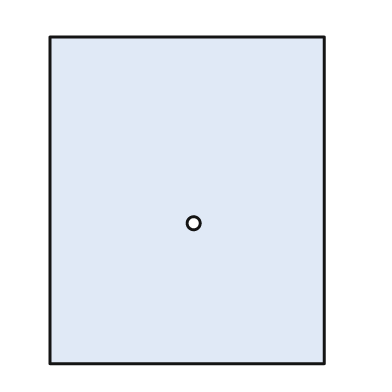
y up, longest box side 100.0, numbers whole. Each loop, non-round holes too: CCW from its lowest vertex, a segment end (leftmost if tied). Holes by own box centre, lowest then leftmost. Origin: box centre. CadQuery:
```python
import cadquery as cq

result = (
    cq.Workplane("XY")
    .moveTo(-42.0, -50.0)
    .lineTo(42.0, -50.0)
    .lineTo(42.0, 50.0)
    .lineTo(-42.0, 50.0)
    .close()
    .moveTo(2.0, -7.0)
    .circle(2.0)
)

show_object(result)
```